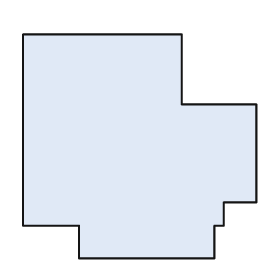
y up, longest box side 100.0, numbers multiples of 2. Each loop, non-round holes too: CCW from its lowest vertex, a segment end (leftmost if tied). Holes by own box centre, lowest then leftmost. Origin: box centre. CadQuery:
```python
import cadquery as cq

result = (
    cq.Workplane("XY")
    .moveTo(-26.0, -48.0)
    .lineTo(32.0, -48.0)
    .lineTo(32.0, -34.0)
    .lineTo(36.0, -34.0)
    .lineTo(36.0, -24.0)
    .lineTo(50.0, -24.0)
    .lineTo(50.0, 18.0)
    .lineTo(18.0, 18.0)
    .lineTo(18.0, 48.0)
    .lineTo(-50.0, 48.0)
    .lineTo(-50.0, -34.0)
    .lineTo(-26.0, -34.0)
    .close()
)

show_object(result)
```